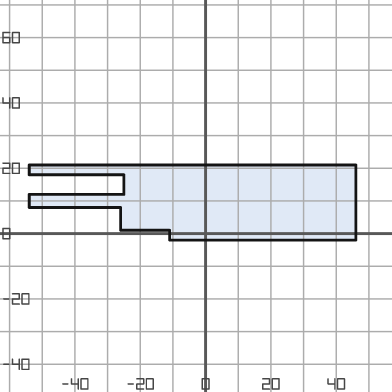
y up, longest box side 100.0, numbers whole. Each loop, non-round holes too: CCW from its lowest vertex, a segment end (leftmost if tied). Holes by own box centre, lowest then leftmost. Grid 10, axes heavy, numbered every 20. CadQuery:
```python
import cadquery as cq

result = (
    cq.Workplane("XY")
    .moveTo(-11.0, -2.0)
    .lineTo(46.0, -2.0)
    .lineTo(46.0, 21.0)
    .lineTo(-54.0, 21.0)
    .lineTo(-54.0, 18.0)
    .lineTo(-25.0, 18.0)
    .lineTo(-25.0, 12.0)
    .lineTo(-54.0, 12.0)
    .lineTo(-54.0, 8.0)
    .lineTo(-26.0, 8.0)
    .lineTo(-26.0, 1.0)
    .lineTo(-11.0, 1.0)
    .close()
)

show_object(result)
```